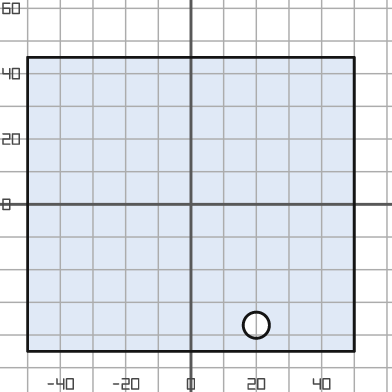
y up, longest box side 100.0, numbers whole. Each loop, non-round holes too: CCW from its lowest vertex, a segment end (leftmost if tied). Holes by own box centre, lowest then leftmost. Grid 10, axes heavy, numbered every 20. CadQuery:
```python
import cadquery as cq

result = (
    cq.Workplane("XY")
    .moveTo(-50.0, -45.0)
    .lineTo(50.0, -45.0)
    .lineTo(50.0, 45.0)
    .lineTo(-50.0, 45.0)
    .close()
    .moveTo(20.0, -37.0)
    .circle(4.0)
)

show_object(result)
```